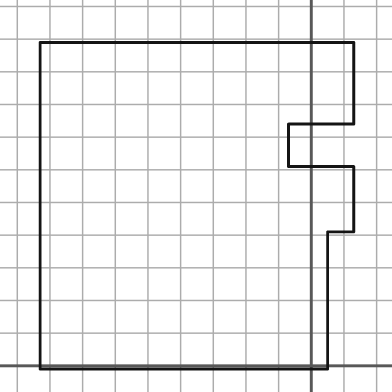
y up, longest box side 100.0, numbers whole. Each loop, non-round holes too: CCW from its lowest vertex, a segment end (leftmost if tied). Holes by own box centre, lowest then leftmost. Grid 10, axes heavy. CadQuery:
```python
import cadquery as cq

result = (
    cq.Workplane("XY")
    .moveTo(-83.0, -1.0)
    .lineTo(5.0, -1.0)
    .lineTo(5.0, 41.0)
    .lineTo(13.0, 41.0)
    .lineTo(13.0, 61.0)
    .lineTo(-7.0, 61.0)
    .lineTo(-7.0, 74.0)
    .lineTo(13.0, 74.0)
    .lineTo(13.0, 99.0)
    .lineTo(-83.0, 99.0)
    .close()
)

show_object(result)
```